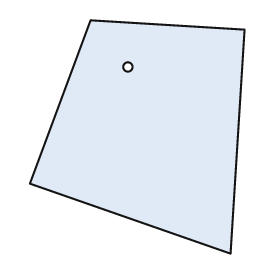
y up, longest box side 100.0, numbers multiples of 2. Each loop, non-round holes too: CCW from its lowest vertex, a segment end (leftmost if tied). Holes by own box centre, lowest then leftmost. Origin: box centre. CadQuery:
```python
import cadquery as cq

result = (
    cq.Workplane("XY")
    .moveTo(40.0, -50.0)
    .lineTo(46.0, 46.0)
    .lineTo(-20.0, 50.0)
    .lineTo(-46.0, -20.0)
    .close()
    .moveTo(-4.0, 30.0)
    .circle(2.0)
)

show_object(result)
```